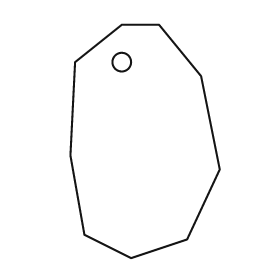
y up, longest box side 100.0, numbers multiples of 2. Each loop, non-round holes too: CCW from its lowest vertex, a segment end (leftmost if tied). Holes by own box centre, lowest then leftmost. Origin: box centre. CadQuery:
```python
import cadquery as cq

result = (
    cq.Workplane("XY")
    .moveTo(-6.0, -50.0)
    .lineTo(18.0, -42.0)
    .lineTo(32.0, -12.0)
    .lineTo(24.0, 28.0)
    .lineTo(6.0, 50.0)
    .lineTo(-10.0, 50.0)
    .lineTo(-30.0, 34.0)
    .lineTo(-32.0, -6.0)
    .lineTo(-26.0, -40.0)
    .close()
    .moveTo(-10.0, 34.0)
    .circle(4.0)
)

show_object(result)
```